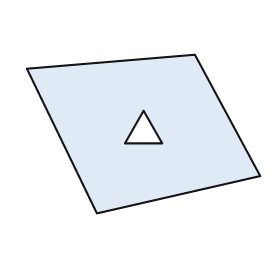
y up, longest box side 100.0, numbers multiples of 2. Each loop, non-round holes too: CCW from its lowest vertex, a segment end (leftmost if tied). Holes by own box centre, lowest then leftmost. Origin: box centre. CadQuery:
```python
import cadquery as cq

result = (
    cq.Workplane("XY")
    .moveTo(-20.0, -34.0)
    .lineTo(50.0, -18.0)
    .lineTo(22.0, 34.0)
    .lineTo(-50.0, 28.0)
    .close()
    .moveTo(-8.0, -4.0)
    .lineTo(8.0, -4.0)
    .lineTo(0.0, 10.0)
    .close()
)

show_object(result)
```